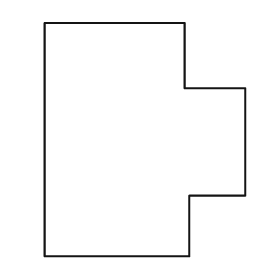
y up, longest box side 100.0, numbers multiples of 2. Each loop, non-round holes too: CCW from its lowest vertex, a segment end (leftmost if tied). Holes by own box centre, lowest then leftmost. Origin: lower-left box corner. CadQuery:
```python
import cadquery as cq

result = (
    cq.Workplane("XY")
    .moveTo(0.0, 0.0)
    .lineTo(62.0, 0.0)
    .lineTo(62.0, 26.0)
    .lineTo(86.0, 26.0)
    .lineTo(86.0, 72.0)
    .lineTo(60.0, 72.0)
    .lineTo(60.0, 100.0)
    .lineTo(0.0, 100.0)
    .close()
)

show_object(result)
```